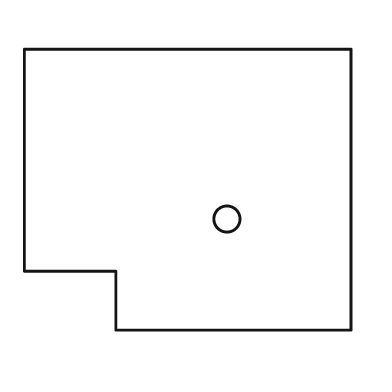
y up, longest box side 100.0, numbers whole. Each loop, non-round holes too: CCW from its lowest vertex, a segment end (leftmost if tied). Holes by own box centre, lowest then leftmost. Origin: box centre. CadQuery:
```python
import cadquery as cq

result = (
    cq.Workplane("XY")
    .moveTo(-22.0, -43.0)
    .lineTo(50.0, -43.0)
    .lineTo(50.0, 43.0)
    .lineTo(-50.0, 43.0)
    .lineTo(-50.0, -25.0)
    .lineTo(-22.0, -25.0)
    .close()
    .moveTo(12.0, -9.0)
    .circle(4.0)
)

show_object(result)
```